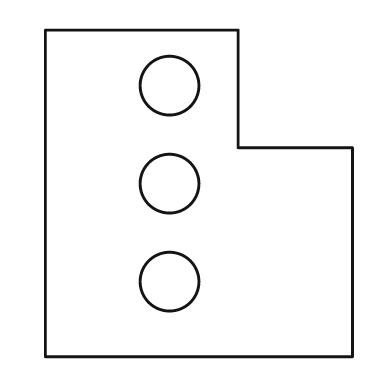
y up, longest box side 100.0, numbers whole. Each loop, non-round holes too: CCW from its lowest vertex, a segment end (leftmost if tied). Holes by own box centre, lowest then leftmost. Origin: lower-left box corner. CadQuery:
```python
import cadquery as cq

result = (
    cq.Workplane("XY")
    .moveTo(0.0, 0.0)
    .lineTo(94.0, 0.0)
    .lineTo(94.0, 64.0)
    .lineTo(59.0, 64.0)
    .lineTo(59.0, 100.0)
    .lineTo(0.0, 100.0)
    .close()
    .moveTo(38.0, 23.0)
    .circle(9.0)
    .moveTo(38.0, 53.0)
    .circle(9.0)
    .moveTo(38.0, 83.0)
    .circle(9.0)
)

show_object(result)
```